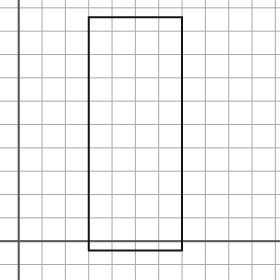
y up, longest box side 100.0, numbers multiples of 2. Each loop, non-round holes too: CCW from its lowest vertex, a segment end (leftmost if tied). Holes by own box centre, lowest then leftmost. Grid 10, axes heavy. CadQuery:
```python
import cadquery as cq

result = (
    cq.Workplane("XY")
    .moveTo(30.0, -4.0)
    .lineTo(70.0, -4.0)
    .lineTo(70.0, 96.0)
    .lineTo(30.0, 96.0)
    .close()
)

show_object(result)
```